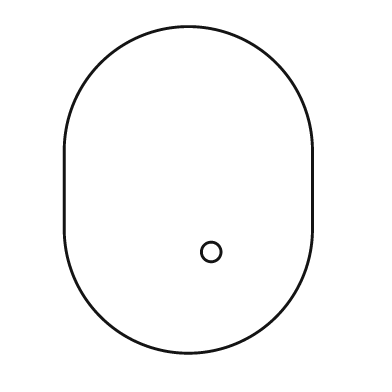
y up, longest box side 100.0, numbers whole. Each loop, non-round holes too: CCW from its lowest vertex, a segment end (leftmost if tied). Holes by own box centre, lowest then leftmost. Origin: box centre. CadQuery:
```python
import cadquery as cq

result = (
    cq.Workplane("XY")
    .moveTo(-38.0, -12.0)
    .threePointArc((0.0, -50.0), (38.0, -12.0))
    .lineTo(38.0, 12.0)
    .threePointArc((0.0, 50.0), (-38.0, 12.0))
    .close()
    .moveTo(7.0, -19.0)
    .circle(3.0)
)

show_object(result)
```